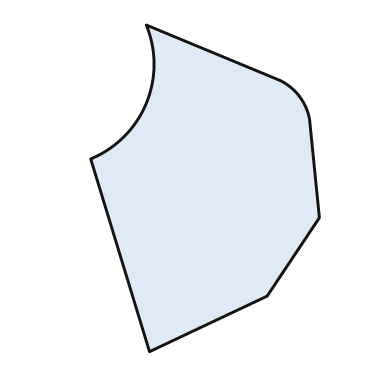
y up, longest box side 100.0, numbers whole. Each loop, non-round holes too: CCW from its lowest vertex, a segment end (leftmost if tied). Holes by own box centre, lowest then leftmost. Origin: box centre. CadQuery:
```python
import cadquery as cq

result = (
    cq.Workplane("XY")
    .moveTo(-17.0, -50.0)
    .lineTo(19.0, -33.0)
    .lineTo(35.0, -9.0)
    .lineTo(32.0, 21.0)
    .threePointArc((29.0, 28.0), (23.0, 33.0))
    .lineTo(-18.0, 50.0)
    .threePointArc((-18.0, 26.0), (-35.0, 9.0))
    .close()
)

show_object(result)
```